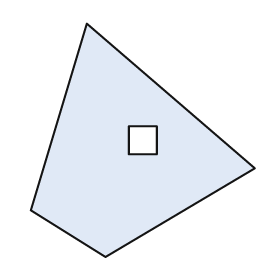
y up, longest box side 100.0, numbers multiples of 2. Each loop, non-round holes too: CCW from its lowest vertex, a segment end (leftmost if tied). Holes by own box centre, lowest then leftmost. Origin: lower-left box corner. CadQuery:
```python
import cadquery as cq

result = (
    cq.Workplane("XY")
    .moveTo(32.0, 0.0)
    .lineTo(96.0, 38.0)
    .lineTo(24.0, 100.0)
    .lineTo(0.0, 20.0)
    .close()
    .moveTo(42.0, 44.0)
    .lineTo(54.0, 44.0)
    .lineTo(54.0, 56.0)
    .lineTo(42.0, 56.0)
    .close()
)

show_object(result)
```